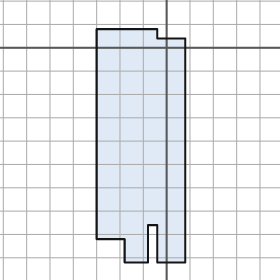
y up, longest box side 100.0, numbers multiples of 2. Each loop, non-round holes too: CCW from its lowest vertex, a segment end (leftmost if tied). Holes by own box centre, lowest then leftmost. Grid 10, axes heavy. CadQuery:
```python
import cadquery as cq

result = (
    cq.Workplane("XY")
    .moveTo(-18.0, -92.0)
    .lineTo(-8.0, -92.0)
    .lineTo(-8.0, -76.0)
    .lineTo(-4.0, -76.0)
    .lineTo(-4.0, -92.0)
    .lineTo(8.0, -92.0)
    .lineTo(8.0, 4.0)
    .lineTo(-4.0, 4.0)
    .lineTo(-4.0, 8.0)
    .lineTo(-30.0, 8.0)
    .lineTo(-30.0, -82.0)
    .lineTo(-18.0, -82.0)
    .close()
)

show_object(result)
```